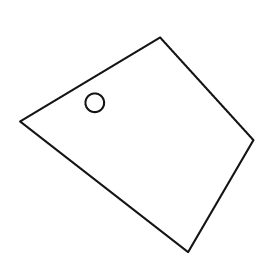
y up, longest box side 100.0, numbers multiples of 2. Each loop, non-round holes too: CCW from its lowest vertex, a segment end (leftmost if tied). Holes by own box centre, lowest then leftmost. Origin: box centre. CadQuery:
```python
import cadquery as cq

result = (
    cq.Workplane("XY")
    .moveTo(22.0, -46.0)
    .lineTo(50.0, 2.0)
    .lineTo(10.0, 46.0)
    .lineTo(-50.0, 10.0)
    .close()
    .moveTo(-18.0, 18.0)
    .circle(4.0)
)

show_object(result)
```